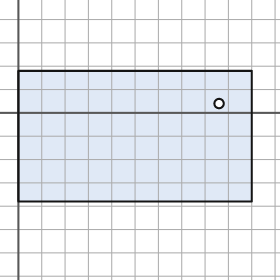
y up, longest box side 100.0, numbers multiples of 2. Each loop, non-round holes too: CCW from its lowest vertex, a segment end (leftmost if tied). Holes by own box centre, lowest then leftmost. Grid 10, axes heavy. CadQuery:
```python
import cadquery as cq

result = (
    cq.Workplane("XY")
    .moveTo(0.0, -38.0)
    .lineTo(100.0, -38.0)
    .lineTo(100.0, 18.0)
    .lineTo(0.0, 18.0)
    .close()
    .moveTo(86.0, 4.0)
    .circle(2.0)
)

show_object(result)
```